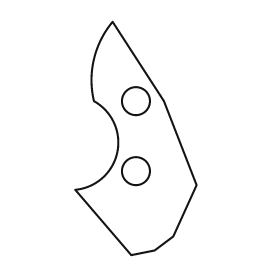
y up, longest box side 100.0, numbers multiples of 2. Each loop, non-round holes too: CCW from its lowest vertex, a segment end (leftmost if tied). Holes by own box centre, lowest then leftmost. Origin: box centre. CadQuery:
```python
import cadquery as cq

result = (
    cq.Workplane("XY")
    .moveTo(-2.0, -50.0)
    .lineTo(8.0, -48.0)
    .lineTo(16.0, -42.0)
    .lineTo(26.0, -20.0)
    .lineTo(12.0, 16.0)
    .lineTo(-10.0, 50.0)
    .threePointArc((-18.0, 34.0), (-18.0, 16.0))
    .threePointArc((-8.0, -6.0), (-26.0, -22.0))
    .close()
    .moveTo(0.0, -14.0)
    .circle(6.0)
    .moveTo(0.0, 16.0)
    .circle(6.0)
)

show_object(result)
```